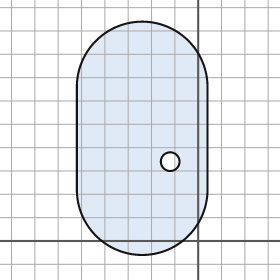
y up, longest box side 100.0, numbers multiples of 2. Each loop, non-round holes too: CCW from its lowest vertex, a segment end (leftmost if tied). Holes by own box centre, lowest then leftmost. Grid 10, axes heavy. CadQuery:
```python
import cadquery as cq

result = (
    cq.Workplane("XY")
    .moveTo(-52.0, 22.0)
    .threePointArc((-24.0, -6.0), (4.0, 22.0))
    .lineTo(4.0, 66.0)
    .threePointArc((-24.0, 94.0), (-52.0, 66.0))
    .close()
    .moveTo(-12.0, 34.0)
    .circle(4.0)
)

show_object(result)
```